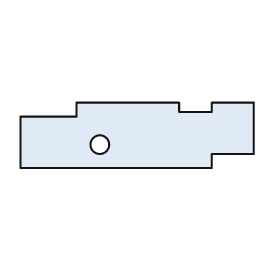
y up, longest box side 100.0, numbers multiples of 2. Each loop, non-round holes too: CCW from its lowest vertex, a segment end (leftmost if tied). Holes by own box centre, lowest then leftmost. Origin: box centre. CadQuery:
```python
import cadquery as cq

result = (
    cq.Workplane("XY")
    .moveTo(-50.0, -14.0)
    .lineTo(32.0, -14.0)
    .lineTo(32.0, -8.0)
    .lineTo(50.0, -8.0)
    .lineTo(50.0, 14.0)
    .lineTo(32.0, 14.0)
    .lineTo(32.0, 10.0)
    .lineTo(18.0, 10.0)
    .lineTo(18.0, 14.0)
    .lineTo(-26.0, 14.0)
    .lineTo(-26.0, 8.0)
    .lineTo(-50.0, 8.0)
    .close()
    .moveTo(-16.0, -4.0)
    .circle(4.0)
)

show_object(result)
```